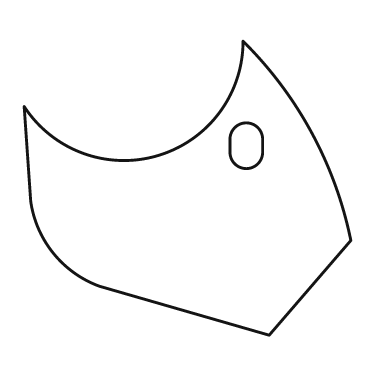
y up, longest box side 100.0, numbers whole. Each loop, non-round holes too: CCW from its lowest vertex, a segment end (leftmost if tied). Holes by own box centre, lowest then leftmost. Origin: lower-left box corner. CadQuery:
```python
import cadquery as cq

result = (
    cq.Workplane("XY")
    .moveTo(75.0, 0.0)
    .lineTo(100.0, 29.0)
    .threePointArc((88.0, 62.0), (67.0, 90.0))
    .threePointArc((41.0, 55.0), (0.0, 70.0))
    .lineTo(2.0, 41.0)
    .threePointArc((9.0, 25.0), (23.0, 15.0))
    .close()
    .moveTo(63.0, 56.0)
    .threePointArc((68.0, 51.0), (73.0, 56.0))
    .lineTo(73.0, 60.0)
    .threePointArc((68.0, 65.0), (63.0, 60.0))
    .close()
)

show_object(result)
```